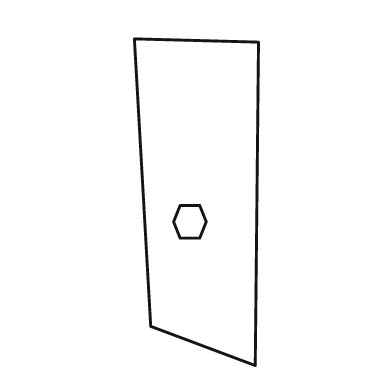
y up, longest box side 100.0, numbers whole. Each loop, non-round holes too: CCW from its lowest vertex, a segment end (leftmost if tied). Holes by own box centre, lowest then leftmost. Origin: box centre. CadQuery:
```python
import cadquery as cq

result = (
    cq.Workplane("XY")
    .moveTo(18.0, -50.0)
    .lineTo(19.0, 49.0)
    .lineTo(-19.0, 50.0)
    .lineTo(-14.0, -38.0)
    .close()
    .moveTo(-5.0, -11.0)
    .lineTo(1.0, -11.0)
    .lineTo(3.0, -6.0)
    .lineTo(1.0, -1.0)
    .lineTo(-5.0, -1.0)
    .lineTo(-7.0, -6.0)
    .close()
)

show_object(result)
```